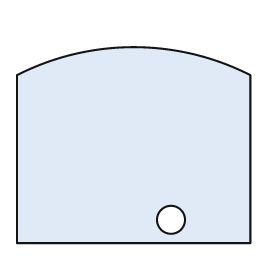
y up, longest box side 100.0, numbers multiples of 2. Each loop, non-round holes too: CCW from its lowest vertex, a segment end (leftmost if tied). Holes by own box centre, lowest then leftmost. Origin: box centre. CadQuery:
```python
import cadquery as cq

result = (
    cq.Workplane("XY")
    .moveTo(-50.0, -42.0)
    .lineTo(50.0, -42.0)
    .lineTo(50.0, 30.0)
    .threePointArc((0.0, 42.0), (-50.0, 30.0))
    .close()
    .moveTo(16.0, -32.0)
    .circle(6.0)
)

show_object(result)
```